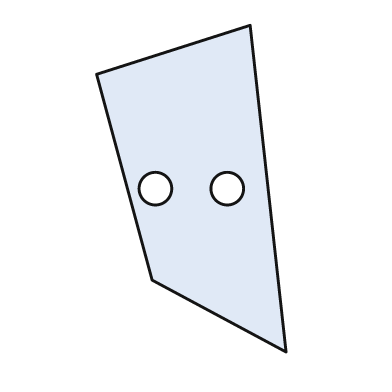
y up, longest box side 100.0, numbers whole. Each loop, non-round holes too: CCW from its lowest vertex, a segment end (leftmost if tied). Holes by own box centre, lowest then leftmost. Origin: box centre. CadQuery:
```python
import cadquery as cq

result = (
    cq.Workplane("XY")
    .moveTo(29.0, -50.0)
    .lineTo(18.0, 50.0)
    .lineTo(-29.0, 35.0)
    .lineTo(-12.0, -28.0)
    .close()
    .moveTo(-11.0, 0.0)
    .circle(5.0)
    .moveTo(11.0, 0.0)
    .circle(5.0)
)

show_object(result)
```